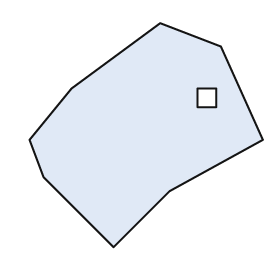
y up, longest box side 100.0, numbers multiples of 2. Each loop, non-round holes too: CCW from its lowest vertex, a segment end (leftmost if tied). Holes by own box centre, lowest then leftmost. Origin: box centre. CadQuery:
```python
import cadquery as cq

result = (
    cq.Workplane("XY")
    .moveTo(-14.0, -48.0)
    .lineTo(10.0, -24.0)
    .lineTo(50.0, -2.0)
    .lineTo(32.0, 38.0)
    .lineTo(6.0, 48.0)
    .lineTo(-32.0, 20.0)
    .lineTo(-50.0, -2.0)
    .lineTo(-44.0, -18.0)
    .close()
    .moveTo(22.0, 12.0)
    .lineTo(30.0, 12.0)
    .lineTo(30.0, 20.0)
    .lineTo(22.0, 20.0)
    .close()
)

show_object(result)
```